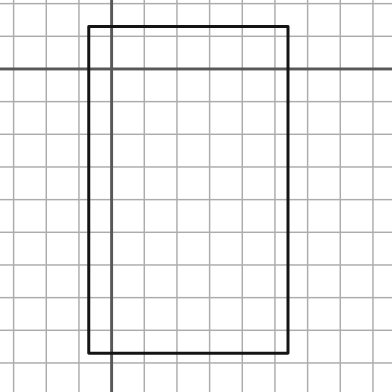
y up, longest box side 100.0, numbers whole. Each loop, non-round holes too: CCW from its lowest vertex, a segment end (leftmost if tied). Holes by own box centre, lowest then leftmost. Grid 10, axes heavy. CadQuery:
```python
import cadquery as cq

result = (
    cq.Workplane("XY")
    .moveTo(-7.0, -87.0)
    .lineTo(54.0, -87.0)
    .lineTo(54.0, 13.0)
    .lineTo(-7.0, 13.0)
    .close()
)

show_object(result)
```